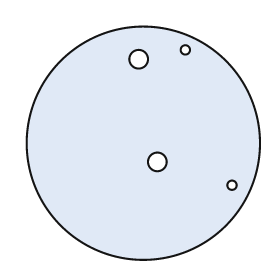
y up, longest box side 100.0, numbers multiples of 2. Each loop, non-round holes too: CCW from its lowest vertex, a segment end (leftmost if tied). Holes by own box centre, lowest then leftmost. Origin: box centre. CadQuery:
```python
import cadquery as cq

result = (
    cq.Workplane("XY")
    .moveTo(0.0, 0.0)
    .circle(50.0)
    .moveTo(38.0, -18.0)
    .circle(2.0)
    .moveTo(6.0, -8.0)
    .circle(4.0)
    .moveTo(-2.0, 36.0)
    .circle(4.0)
    .moveTo(18.0, 40.0)
    .circle(2.0)
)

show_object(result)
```